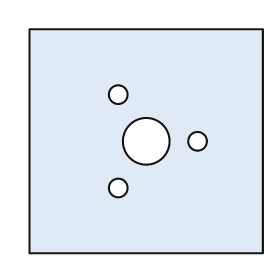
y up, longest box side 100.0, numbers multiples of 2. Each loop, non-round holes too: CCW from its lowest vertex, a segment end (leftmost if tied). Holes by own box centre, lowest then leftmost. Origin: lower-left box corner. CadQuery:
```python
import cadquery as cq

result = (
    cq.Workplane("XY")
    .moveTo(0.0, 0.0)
    .lineTo(100.0, 0.0)
    .lineTo(100.0, 96.0)
    .lineTo(0.0, 96.0)
    .close()
    .moveTo(38.0, 28.0)
    .circle(4.0)
    .moveTo(50.0, 48.0)
    .circle(10.0)
    .moveTo(72.0, 48.0)
    .circle(4.0)
    .moveTo(38.0, 68.0)
    .circle(4.0)
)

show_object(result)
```